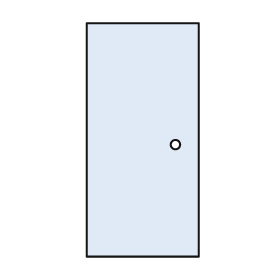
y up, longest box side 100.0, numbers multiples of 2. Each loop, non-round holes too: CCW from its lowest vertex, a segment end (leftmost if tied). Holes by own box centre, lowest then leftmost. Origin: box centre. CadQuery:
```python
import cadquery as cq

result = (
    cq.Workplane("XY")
    .moveTo(-24.0, -50.0)
    .lineTo(24.0, -50.0)
    .lineTo(24.0, 50.0)
    .lineTo(-24.0, 50.0)
    .close()
    .moveTo(14.0, -2.0)
    .circle(2.0)
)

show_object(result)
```